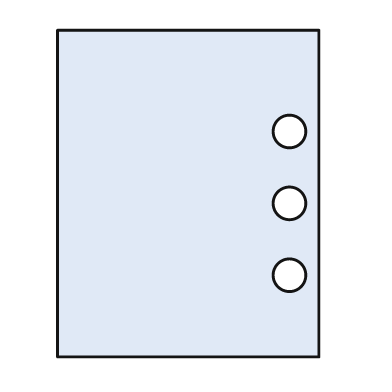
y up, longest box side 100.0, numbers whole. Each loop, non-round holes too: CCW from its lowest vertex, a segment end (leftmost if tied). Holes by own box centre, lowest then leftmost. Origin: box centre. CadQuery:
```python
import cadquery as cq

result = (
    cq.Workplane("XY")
    .moveTo(-40.0, -50.0)
    .lineTo(40.0, -50.0)
    .lineTo(40.0, 50.0)
    .lineTo(-40.0, 50.0)
    .close()
    .moveTo(31.0, -25.0)
    .circle(5.0)
    .moveTo(31.0, -3.0)
    .circle(5.0)
    .moveTo(31.0, 19.0)
    .circle(5.0)
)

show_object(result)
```